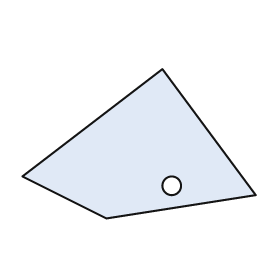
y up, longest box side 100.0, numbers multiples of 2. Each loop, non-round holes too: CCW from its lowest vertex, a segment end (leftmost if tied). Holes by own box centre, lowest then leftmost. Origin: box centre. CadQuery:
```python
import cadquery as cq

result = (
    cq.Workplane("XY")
    .moveTo(-14.0, -32.0)
    .lineTo(50.0, -22.0)
    .lineTo(10.0, 32.0)
    .lineTo(-50.0, -14.0)
    .close()
    .moveTo(14.0, -18.0)
    .circle(4.0)
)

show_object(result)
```